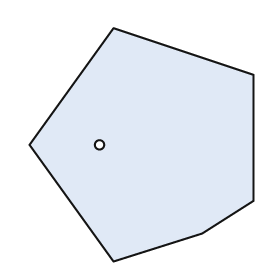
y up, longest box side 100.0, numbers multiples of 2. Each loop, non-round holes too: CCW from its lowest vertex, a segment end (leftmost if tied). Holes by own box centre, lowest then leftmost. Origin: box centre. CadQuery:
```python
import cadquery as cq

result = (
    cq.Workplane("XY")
    .moveTo(-12.0, -50.0)
    .lineTo(26.0, -38.0)
    .lineTo(48.0, -24.0)
    .lineTo(48.0, 30.0)
    .lineTo(-12.0, 50.0)
    .lineTo(-48.0, 0.0)
    .close()
    .moveTo(-18.0, 0.0)
    .circle(2.0)
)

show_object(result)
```